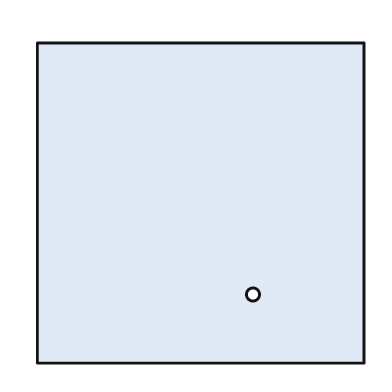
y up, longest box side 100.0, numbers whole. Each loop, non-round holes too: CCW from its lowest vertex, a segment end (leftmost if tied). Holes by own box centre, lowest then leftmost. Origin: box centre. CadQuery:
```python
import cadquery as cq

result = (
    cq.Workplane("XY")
    .moveTo(-50.0, -49.0)
    .lineTo(50.0, -49.0)
    .lineTo(50.0, 49.0)
    .lineTo(-50.0, 49.0)
    .close()
    .moveTo(16.0, -28.0)
    .circle(2.0)
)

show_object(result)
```